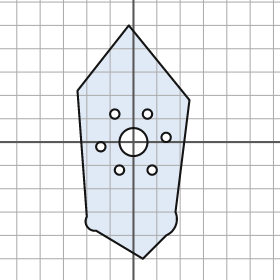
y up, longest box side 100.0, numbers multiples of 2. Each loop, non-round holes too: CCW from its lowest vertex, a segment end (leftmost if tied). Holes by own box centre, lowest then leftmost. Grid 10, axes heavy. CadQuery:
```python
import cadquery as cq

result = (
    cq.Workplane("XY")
    .moveTo(4.0, -50.0)
    .lineTo(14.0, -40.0)
    .threePointArc((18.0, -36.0), (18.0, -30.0))
    .lineTo(24.0, 18.0)
    .lineTo(-2.0, 50.0)
    .lineTo(-24.0, 22.0)
    .lineTo(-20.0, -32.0)
    .threePointArc((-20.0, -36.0), (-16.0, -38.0))
    .close()
    .moveTo(-6.0, -12.0)
    .circle(2.0)
    .moveTo(8.0, -12.0)
    .circle(2.0)
    .moveTo(-14.0, -2.0)
    .circle(2.0)
    .moveTo(0.0, 0.0)
    .circle(6.0)
    .moveTo(14.0, 2.0)
    .circle(2.0)
    .moveTo(-8.0, 12.0)
    .circle(2.0)
    .moveTo(6.0, 12.0)
    .circle(2.0)
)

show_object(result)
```